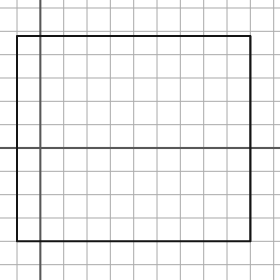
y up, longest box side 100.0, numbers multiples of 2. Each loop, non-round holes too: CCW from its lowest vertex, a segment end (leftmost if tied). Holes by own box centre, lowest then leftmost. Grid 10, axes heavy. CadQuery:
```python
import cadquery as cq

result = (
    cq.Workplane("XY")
    .moveTo(-10.0, -40.0)
    .lineTo(90.0, -40.0)
    .lineTo(90.0, 48.0)
    .lineTo(-10.0, 48.0)
    .close()
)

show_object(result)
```